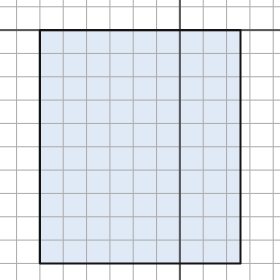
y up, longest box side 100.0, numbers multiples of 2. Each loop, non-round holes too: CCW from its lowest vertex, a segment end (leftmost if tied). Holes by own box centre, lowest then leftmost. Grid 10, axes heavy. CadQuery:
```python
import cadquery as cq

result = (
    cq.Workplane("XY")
    .moveTo(-60.0, -100.0)
    .lineTo(26.0, -100.0)
    .lineTo(26.0, 0.0)
    .lineTo(-60.0, 0.0)
    .close()
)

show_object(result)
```